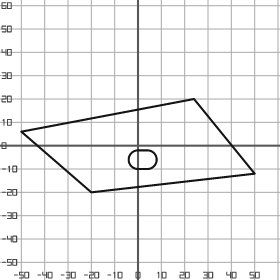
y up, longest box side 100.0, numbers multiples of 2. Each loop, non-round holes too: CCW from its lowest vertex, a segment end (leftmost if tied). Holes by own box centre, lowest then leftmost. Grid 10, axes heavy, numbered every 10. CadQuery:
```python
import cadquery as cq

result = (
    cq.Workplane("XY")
    .moveTo(-20.0, -20.0)
    .lineTo(50.0, -12.0)
    .lineTo(24.0, 20.0)
    .lineTo(-50.0, 6.0)
    .close()
    .moveTo(0.0, -10.0)
    .lineTo(4.0, -10.0)
    .threePointArc((8.0, -6.0), (4.0, -2.0))
    .lineTo(0.0, -2.0)
    .threePointArc((-4.0, -6.0), (0.0, -10.0))
    .close()
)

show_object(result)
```